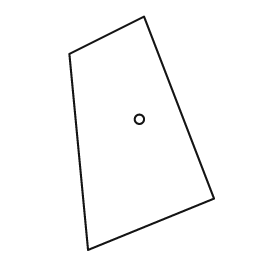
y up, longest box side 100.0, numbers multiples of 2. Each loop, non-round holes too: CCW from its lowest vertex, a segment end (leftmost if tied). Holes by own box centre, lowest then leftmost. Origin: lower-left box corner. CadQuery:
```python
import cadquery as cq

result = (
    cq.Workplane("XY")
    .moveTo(8.0, 0.0)
    .lineTo(62.0, 22.0)
    .lineTo(32.0, 100.0)
    .lineTo(0.0, 84.0)
    .close()
    .moveTo(30.0, 56.0)
    .circle(2.0)
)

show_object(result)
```